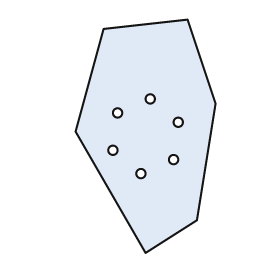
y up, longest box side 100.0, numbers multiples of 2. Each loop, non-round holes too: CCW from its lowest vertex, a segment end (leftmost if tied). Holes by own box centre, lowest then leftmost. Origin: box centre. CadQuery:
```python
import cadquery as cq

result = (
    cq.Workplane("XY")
    .moveTo(0.0, -50.0)
    .lineTo(22.0, -36.0)
    .lineTo(30.0, 14.0)
    .lineTo(18.0, 50.0)
    .lineTo(-18.0, 46.0)
    .lineTo(-30.0, 2.0)
    .close()
    .moveTo(-2.0, -16.0)
    .circle(2.0)
    .moveTo(12.0, -10.0)
    .circle(2.0)
    .moveTo(-14.0, -6.0)
    .circle(2.0)
    .moveTo(14.0, 6.0)
    .circle(2.0)
    .moveTo(-12.0, 10.0)
    .circle(2.0)
    .moveTo(2.0, 16.0)
    .circle(2.0)
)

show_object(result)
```